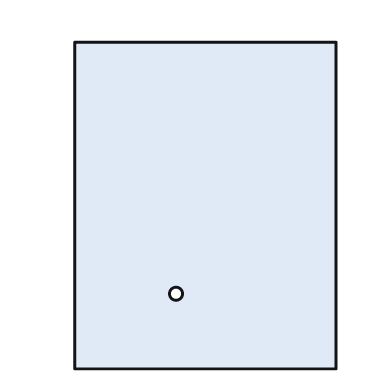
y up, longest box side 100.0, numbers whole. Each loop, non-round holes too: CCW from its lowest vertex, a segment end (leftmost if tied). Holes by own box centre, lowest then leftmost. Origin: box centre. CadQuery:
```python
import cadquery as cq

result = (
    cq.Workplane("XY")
    .moveTo(-40.0, -50.0)
    .lineTo(40.0, -50.0)
    .lineTo(40.0, 50.0)
    .lineTo(-40.0, 50.0)
    .close()
    .moveTo(-9.0, -27.0)
    .circle(2.0)
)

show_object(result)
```